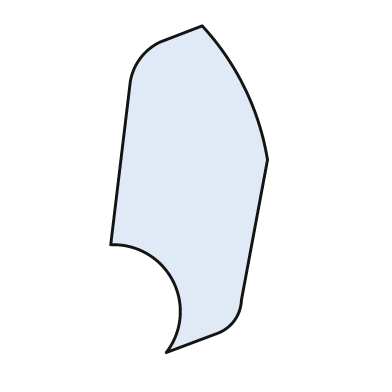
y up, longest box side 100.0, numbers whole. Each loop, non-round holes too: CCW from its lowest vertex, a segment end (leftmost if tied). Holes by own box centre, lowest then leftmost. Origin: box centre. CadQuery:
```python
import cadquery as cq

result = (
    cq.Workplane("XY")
    .moveTo(-7.0, -50.0)
    .lineTo(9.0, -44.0)
    .threePointArc((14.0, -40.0), (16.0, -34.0))
    .lineTo(24.0, 9.0)
    .threePointArc((17.0, 31.0), (4.0, 50.0))
    .lineTo(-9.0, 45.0)
    .threePointArc((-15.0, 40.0), (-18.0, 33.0))
    .lineTo(-24.0, -17.0)
    .threePointArc((-5.0, -28.0), (-7.0, -50.0))
    .close()
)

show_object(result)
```